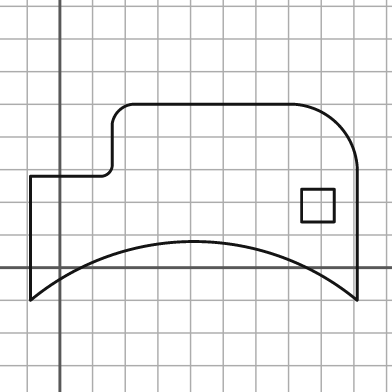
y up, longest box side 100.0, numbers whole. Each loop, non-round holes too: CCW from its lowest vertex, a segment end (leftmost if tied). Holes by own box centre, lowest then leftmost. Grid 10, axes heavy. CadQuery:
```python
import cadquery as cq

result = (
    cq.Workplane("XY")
    .moveTo(-9.0, -10.0)
    .threePointArc((41.0, 8.0), (91.0, -10.0))
    .lineTo(91.0, 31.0)
    .threePointArc((85.0, 44.0), (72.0, 50.0))
    .lineTo(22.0, 50.0)
    .threePointArc((18.0, 48.0), (16.0, 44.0))
    .lineTo(16.0, 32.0)
    .threePointArc((15.0, 29.0), (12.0, 28.0))
    .lineTo(-9.0, 28.0)
    .close()
    .moveTo(74.0, 14.0)
    .lineTo(84.0, 14.0)
    .lineTo(84.0, 24.0)
    .lineTo(74.0, 24.0)
    .close()
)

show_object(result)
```